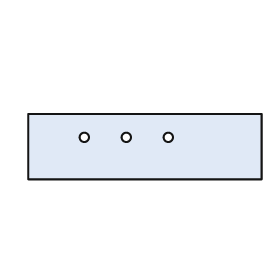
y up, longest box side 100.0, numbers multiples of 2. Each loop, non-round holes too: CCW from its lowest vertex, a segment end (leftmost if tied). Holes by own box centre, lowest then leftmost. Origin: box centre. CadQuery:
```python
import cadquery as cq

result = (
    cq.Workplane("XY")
    .moveTo(-50.0, -14.0)
    .lineTo(50.0, -14.0)
    .lineTo(50.0, 14.0)
    .lineTo(-50.0, 14.0)
    .close()
    .moveTo(-26.0, 4.0)
    .circle(2.0)
    .moveTo(-8.0, 4.0)
    .circle(2.0)
    .moveTo(10.0, 4.0)
    .circle(2.0)
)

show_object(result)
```